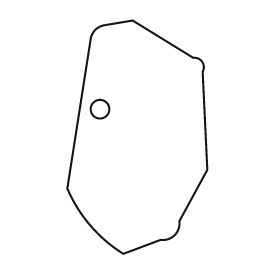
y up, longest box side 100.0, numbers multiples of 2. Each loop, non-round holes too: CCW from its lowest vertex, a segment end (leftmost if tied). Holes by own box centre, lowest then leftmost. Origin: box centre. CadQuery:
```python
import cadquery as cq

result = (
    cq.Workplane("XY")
    .moveTo(-6.0, -50.0)
    .lineTo(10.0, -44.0)
    .threePointArc((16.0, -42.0), (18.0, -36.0))
    .lineTo(30.0, -14.0)
    .lineTo(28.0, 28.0)
    .threePointArc((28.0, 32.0), (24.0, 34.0))
    .lineTo(-2.0, 50.0)
    .lineTo(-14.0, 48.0)
    .threePointArc((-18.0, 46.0), (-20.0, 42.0))
    .lineTo(-30.0, -22.0)
    .threePointArc((-20.0, -38.0), (-6.0, -50.0))
    .close()
    .moveTo(-16.0, 12.0)
    .circle(4.0)
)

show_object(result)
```